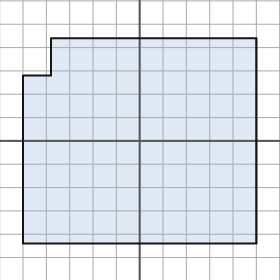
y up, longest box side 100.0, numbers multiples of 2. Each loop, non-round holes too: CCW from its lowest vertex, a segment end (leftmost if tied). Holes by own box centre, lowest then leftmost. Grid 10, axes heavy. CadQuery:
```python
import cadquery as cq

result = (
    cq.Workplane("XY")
    .moveTo(-50.0, -44.0)
    .lineTo(50.0, -44.0)
    .lineTo(50.0, 44.0)
    .lineTo(-38.0, 44.0)
    .lineTo(-38.0, 28.0)
    .lineTo(-50.0, 28.0)
    .close()
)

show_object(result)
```